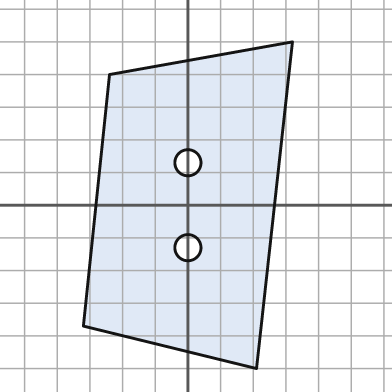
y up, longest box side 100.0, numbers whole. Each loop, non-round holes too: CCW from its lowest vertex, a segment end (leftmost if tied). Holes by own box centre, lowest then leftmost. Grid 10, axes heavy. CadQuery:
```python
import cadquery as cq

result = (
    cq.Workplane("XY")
    .moveTo(21.0, -50.0)
    .lineTo(32.0, 50.0)
    .lineTo(-24.0, 40.0)
    .lineTo(-32.0, -37.0)
    .close()
    .moveTo(0.0, -13.0)
    .circle(4.0)
    .moveTo(0.0, 13.0)
    .circle(4.0)
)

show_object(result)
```